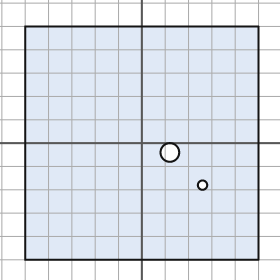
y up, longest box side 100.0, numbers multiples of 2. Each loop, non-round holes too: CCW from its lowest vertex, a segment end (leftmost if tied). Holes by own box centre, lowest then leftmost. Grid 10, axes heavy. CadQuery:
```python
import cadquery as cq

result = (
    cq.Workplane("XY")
    .moveTo(-50.0, -50.0)
    .lineTo(50.0, -50.0)
    .lineTo(50.0, 50.0)
    .lineTo(-50.0, 50.0)
    .close()
    .moveTo(26.0, -18.0)
    .circle(2.0)
    .moveTo(12.0, -4.0)
    .circle(4.0)
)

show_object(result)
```